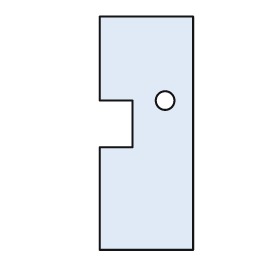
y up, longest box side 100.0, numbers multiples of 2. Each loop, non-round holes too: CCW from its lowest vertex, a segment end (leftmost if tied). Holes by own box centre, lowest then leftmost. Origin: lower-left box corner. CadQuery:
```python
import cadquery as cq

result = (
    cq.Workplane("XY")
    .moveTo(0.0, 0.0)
    .lineTo(40.0, 0.0)
    .lineTo(40.0, 100.0)
    .lineTo(0.0, 100.0)
    .lineTo(0.0, 64.0)
    .lineTo(14.0, 64.0)
    .lineTo(14.0, 44.0)
    .lineTo(0.0, 44.0)
    .close()
    .moveTo(28.0, 64.0)
    .circle(4.0)
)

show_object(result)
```